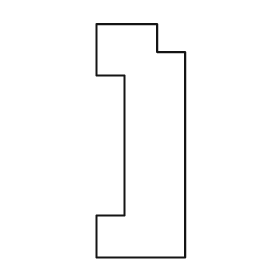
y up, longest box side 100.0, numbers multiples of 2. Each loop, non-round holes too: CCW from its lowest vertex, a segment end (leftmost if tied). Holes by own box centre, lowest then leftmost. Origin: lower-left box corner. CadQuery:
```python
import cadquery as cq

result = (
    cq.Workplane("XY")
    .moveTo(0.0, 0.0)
    .lineTo(38.0, 0.0)
    .lineTo(38.0, 88.0)
    .lineTo(26.0, 88.0)
    .lineTo(26.0, 100.0)
    .lineTo(0.0, 100.0)
    .lineTo(0.0, 78.0)
    .lineTo(12.0, 78.0)
    .lineTo(12.0, 18.0)
    .lineTo(0.0, 18.0)
    .close()
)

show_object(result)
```